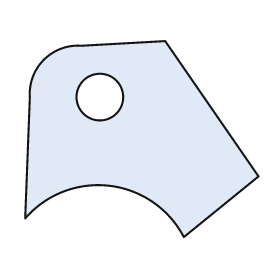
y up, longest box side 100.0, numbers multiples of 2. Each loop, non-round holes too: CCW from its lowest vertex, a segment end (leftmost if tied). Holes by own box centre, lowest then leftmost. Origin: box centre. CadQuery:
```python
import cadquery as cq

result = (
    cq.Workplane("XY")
    .moveTo(18.0, -42.0)
    .lineTo(50.0, -16.0)
    .lineTo(10.0, 42.0)
    .lineTo(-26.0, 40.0)
    .threePointArc((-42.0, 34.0), (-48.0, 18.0))
    .lineTo(-50.0, -34.0)
    .threePointArc((-14.0, -20.0), (18.0, -42.0))
    .close()
    .moveTo(-18.0, 18.0)
    .circle(10.0)
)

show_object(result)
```